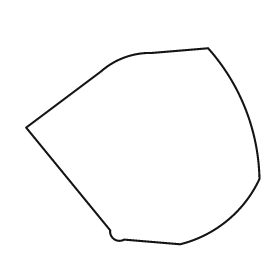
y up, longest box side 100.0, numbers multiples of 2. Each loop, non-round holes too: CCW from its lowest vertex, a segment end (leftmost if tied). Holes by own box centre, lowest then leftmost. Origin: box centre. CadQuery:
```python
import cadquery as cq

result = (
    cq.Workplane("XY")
    .moveTo(16.0, -42.0)
    .threePointArc((36.0, -32.0), (50.0, -14.0))
    .threePointArc((44.0, 16.0), (28.0, 42.0))
    .lineTo(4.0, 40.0)
    .threePointArc((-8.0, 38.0), (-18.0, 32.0))
    .lineTo(-50.0, 8.0)
    .lineTo(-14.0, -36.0)
    .threePointArc((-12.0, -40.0), (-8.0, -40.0))
    .close()
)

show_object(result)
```